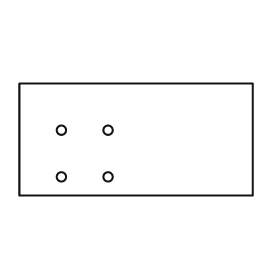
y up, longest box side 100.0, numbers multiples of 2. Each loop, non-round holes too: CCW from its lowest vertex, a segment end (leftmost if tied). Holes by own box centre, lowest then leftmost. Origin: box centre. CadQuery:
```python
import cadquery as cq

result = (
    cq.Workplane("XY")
    .moveTo(-50.0, -24.0)
    .lineTo(50.0, -24.0)
    .lineTo(50.0, 24.0)
    .lineTo(-50.0, 24.0)
    .close()
    .moveTo(-32.0, -16.0)
    .circle(2.0)
    .moveTo(-12.0, -16.0)
    .circle(2.0)
    .moveTo(-32.0, 4.0)
    .circle(2.0)
    .moveTo(-12.0, 4.0)
    .circle(2.0)
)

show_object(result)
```